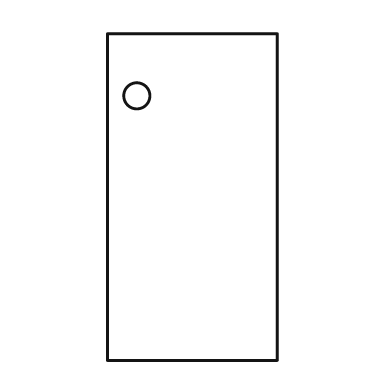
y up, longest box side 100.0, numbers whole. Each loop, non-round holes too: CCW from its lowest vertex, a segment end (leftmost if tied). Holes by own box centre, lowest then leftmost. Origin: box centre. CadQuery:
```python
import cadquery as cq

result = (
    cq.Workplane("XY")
    .moveTo(-26.0, -50.0)
    .lineTo(26.0, -50.0)
    .lineTo(26.0, 50.0)
    .lineTo(-26.0, 50.0)
    .close()
    .moveTo(-17.0, 31.0)
    .circle(4.0)
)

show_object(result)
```